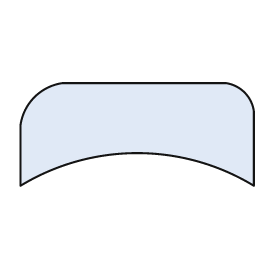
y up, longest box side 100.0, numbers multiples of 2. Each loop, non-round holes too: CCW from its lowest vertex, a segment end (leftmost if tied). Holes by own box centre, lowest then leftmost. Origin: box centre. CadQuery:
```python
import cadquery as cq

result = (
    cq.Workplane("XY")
    .moveTo(-50.0, -22.0)
    .threePointArc((0.0, -8.0), (50.0, -22.0))
    .lineTo(50.0, 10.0)
    .threePointArc((46.0, 18.0), (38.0, 22.0))
    .lineTo(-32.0, 22.0)
    .threePointArc((-44.0, 16.0), (-50.0, 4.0))
    .close()
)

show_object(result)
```